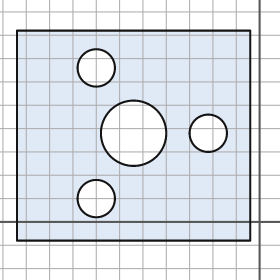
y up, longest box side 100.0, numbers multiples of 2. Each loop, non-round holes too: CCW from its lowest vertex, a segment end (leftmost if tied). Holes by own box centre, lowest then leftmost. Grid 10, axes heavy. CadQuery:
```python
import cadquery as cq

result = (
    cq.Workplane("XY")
    .moveTo(-104.0, -8.0)
    .lineTo(-4.0, -8.0)
    .lineTo(-4.0, 82.0)
    .lineTo(-104.0, 82.0)
    .close()
    .moveTo(-70.0, 10.0)
    .circle(8.0)
    .moveTo(-54.0, 38.0)
    .circle(14.0)
    .moveTo(-22.0, 38.0)
    .circle(8.0)
    .moveTo(-70.0, 66.0)
    .circle(8.0)
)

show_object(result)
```